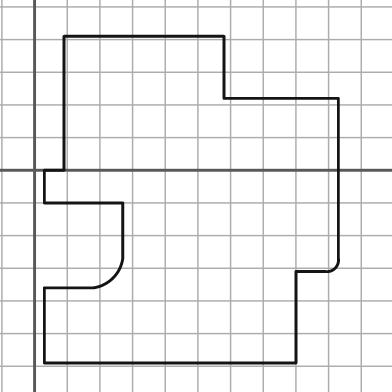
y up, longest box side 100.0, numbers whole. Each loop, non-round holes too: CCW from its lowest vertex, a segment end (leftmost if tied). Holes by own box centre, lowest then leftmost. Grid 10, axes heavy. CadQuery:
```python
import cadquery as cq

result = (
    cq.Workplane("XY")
    .moveTo(3.0, -59.0)
    .lineTo(80.0, -59.0)
    .lineTo(80.0, -31.0)
    .lineTo(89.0, -31.0)
    .threePointArc((92.0, -30.0), (93.0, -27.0))
    .lineTo(93.0, 22.0)
    .lineTo(58.0, 22.0)
    .lineTo(58.0, 41.0)
    .lineTo(9.0, 41.0)
    .lineTo(9.0, 0.0)
    .lineTo(3.0, 0.0)
    .lineTo(3.0, -10.0)
    .lineTo(27.0, -10.0)
    .lineTo(27.0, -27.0)
    .threePointArc((24.0, -33.0), (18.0, -36.0))
    .lineTo(3.0, -36.0)
    .close()
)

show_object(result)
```